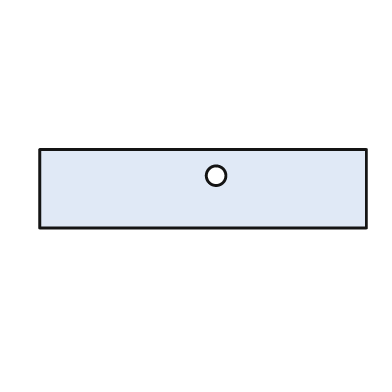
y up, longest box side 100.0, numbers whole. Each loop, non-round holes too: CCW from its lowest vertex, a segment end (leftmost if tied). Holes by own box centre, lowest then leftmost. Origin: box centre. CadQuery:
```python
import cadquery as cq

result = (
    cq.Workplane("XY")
    .moveTo(-50.0, -12.0)
    .lineTo(50.0, -12.0)
    .lineTo(50.0, 12.0)
    .lineTo(-50.0, 12.0)
    .close()
    .moveTo(4.0, 4.0)
    .circle(3.0)
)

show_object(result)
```